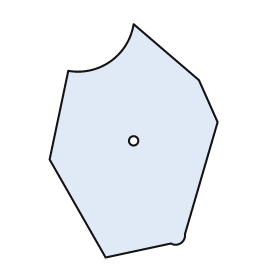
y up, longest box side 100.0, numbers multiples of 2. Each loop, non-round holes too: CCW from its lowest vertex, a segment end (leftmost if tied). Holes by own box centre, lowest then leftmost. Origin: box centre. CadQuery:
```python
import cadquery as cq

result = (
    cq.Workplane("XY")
    .moveTo(-12.0, -50.0)
    .lineTo(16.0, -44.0)
    .threePointArc((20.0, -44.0), (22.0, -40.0))
    .lineTo(36.0, 8.0)
    .lineTo(28.0, 26.0)
    .lineTo(0.0, 50.0)
    .threePointArc((-10.0, 34.0), (-28.0, 30.0))
    .lineTo(-36.0, -8.0)
    .close()
    .moveTo(0.0, 0.0)
    .circle(2.0)
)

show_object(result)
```